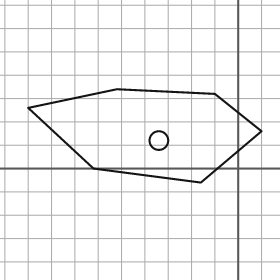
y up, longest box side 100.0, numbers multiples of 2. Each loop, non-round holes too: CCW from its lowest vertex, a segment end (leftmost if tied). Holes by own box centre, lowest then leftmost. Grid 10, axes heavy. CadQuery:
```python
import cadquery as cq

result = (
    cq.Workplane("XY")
    .moveTo(-16.0, -6.0)
    .lineTo(10.0, 16.0)
    .lineTo(-10.0, 32.0)
    .lineTo(-52.0, 34.0)
    .lineTo(-90.0, 26.0)
    .lineTo(-62.0, 0.0)
    .close()
    .moveTo(-34.0, 12.0)
    .circle(4.0)
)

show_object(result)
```